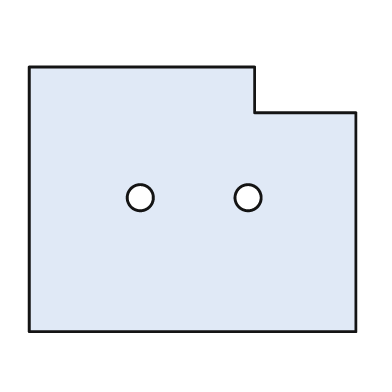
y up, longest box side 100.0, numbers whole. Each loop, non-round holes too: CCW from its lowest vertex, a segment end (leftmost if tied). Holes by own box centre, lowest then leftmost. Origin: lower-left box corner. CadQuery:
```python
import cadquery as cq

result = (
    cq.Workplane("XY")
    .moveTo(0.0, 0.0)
    .lineTo(100.0, 0.0)
    .lineTo(100.0, 67.0)
    .lineTo(69.0, 67.0)
    .lineTo(69.0, 81.0)
    .lineTo(0.0, 81.0)
    .close()
    .moveTo(34.0, 41.0)
    .circle(4.0)
    .moveTo(67.0, 41.0)
    .circle(4.0)
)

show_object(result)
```